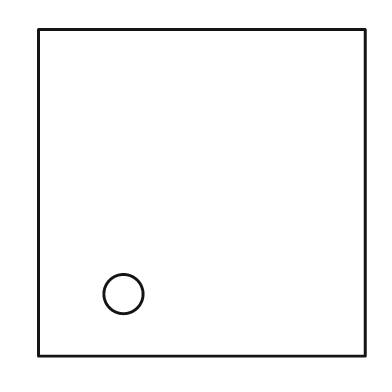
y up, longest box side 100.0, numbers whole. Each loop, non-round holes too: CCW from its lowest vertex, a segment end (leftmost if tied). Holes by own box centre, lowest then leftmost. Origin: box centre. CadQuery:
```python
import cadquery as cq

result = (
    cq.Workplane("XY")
    .moveTo(-50.0, -50.0)
    .lineTo(50.0, -50.0)
    .lineTo(50.0, 50.0)
    .lineTo(-50.0, 50.0)
    .close()
    .moveTo(-24.0, -31.0)
    .circle(6.0)
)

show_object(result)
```